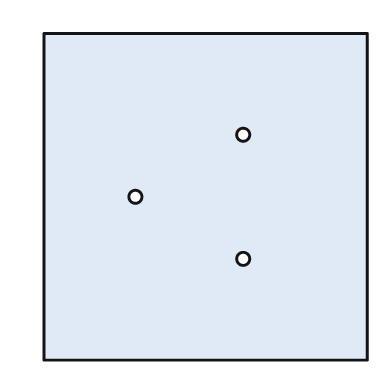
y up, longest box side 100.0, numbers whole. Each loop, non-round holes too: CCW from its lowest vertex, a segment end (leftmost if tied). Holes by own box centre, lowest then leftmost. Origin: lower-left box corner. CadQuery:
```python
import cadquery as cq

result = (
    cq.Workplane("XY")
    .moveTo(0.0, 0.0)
    .lineTo(99.0, 0.0)
    .lineTo(99.0, 100.0)
    .lineTo(0.0, 100.0)
    .close()
    .moveTo(61.0, 31.0)
    .circle(2.0)
    .moveTo(28.0, 50.0)
    .circle(2.0)
    .moveTo(61.0, 69.0)
    .circle(2.0)
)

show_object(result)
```